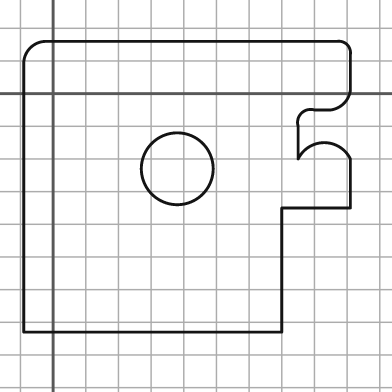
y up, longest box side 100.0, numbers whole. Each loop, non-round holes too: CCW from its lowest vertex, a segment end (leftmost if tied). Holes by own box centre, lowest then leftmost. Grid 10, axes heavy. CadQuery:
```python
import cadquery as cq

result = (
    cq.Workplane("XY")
    .moveTo(-9.0, -73.0)
    .lineTo(70.0, -73.0)
    .lineTo(70.0, -35.0)
    .lineTo(91.0, -35.0)
    .lineTo(91.0, -20.0)
    .threePointArc((83.0, -15.0), (75.0, -20.0))
    .lineTo(75.0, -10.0)
    .threePointArc((76.0, -6.0), (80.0, -5.0))
    .lineTo(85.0, -5.0)
    .threePointArc((89.0, -3.0), (91.0, 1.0))
    .lineTo(91.0, 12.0)
    .threePointArc((90.0, 15.0), (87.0, 16.0))
    .lineTo(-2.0, 16.0)
    .threePointArc((-7.0, 14.0), (-9.0, 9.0))
    .close()
    .moveTo(38.0, -23.0)
    .circle(11.0)
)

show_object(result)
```